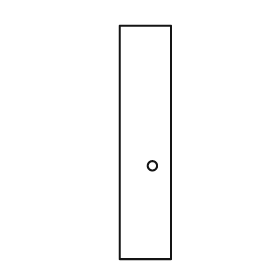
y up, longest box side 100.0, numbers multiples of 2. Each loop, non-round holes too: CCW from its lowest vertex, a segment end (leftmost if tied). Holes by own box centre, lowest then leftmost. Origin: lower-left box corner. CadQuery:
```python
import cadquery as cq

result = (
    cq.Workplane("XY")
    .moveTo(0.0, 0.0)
    .lineTo(22.0, 0.0)
    .lineTo(22.0, 100.0)
    .lineTo(0.0, 100.0)
    .close()
    .moveTo(14.0, 40.0)
    .circle(2.0)
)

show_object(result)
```